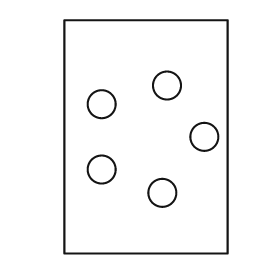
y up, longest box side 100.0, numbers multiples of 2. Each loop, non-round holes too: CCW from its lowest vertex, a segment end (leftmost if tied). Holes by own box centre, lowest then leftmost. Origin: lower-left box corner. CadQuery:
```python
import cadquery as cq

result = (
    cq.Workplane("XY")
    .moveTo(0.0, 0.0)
    .lineTo(70.0, 0.0)
    .lineTo(70.0, 100.0)
    .lineTo(0.0, 100.0)
    .close()
    .moveTo(42.0, 26.0)
    .circle(6.0)
    .moveTo(16.0, 36.0)
    .circle(6.0)
    .moveTo(60.0, 50.0)
    .circle(6.0)
    .moveTo(16.0, 64.0)
    .circle(6.0)
    .moveTo(44.0, 72.0)
    .circle(6.0)
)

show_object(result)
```